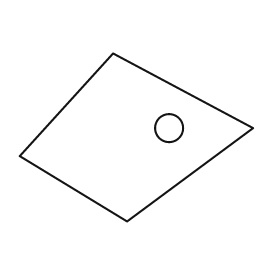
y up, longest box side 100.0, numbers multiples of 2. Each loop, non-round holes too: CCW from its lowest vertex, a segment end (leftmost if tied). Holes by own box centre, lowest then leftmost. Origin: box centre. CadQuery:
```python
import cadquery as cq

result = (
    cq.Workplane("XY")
    .moveTo(-4.0, -36.0)
    .lineTo(50.0, 4.0)
    .lineTo(-10.0, 36.0)
    .lineTo(-50.0, -8.0)
    .close()
    .moveTo(14.0, 4.0)
    .circle(6.0)
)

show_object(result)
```